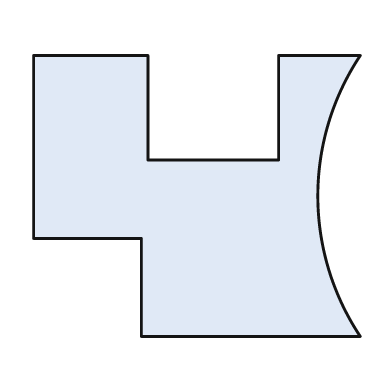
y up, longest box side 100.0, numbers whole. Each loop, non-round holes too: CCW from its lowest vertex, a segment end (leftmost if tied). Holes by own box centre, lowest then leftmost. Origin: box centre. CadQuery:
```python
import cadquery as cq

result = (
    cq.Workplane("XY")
    .moveTo(-17.0, -43.0)
    .lineTo(50.0, -43.0)
    .threePointArc((37.0, 0.0), (50.0, 43.0))
    .lineTo(25.0, 43.0)
    .lineTo(25.0, 11.0)
    .lineTo(-15.0, 11.0)
    .lineTo(-15.0, 43.0)
    .lineTo(-50.0, 43.0)
    .lineTo(-50.0, -13.0)
    .lineTo(-17.0, -13.0)
    .close()
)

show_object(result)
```